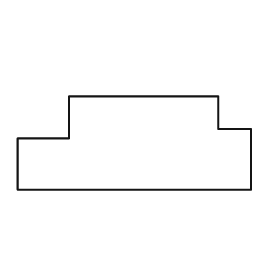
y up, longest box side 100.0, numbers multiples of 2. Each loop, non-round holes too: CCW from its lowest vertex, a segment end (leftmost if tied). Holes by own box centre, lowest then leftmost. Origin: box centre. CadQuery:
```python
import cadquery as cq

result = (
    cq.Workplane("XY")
    .moveTo(-50.0, -20.0)
    .lineTo(50.0, -20.0)
    .lineTo(50.0, 6.0)
    .lineTo(36.0, 6.0)
    .lineTo(36.0, 20.0)
    .lineTo(-28.0, 20.0)
    .lineTo(-28.0, 2.0)
    .lineTo(-50.0, 2.0)
    .close()
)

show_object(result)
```